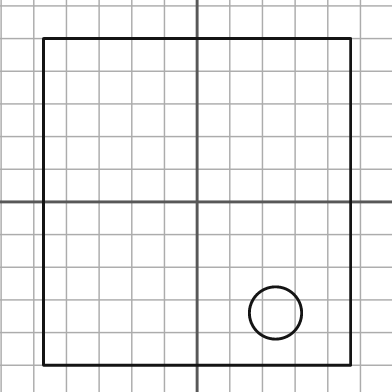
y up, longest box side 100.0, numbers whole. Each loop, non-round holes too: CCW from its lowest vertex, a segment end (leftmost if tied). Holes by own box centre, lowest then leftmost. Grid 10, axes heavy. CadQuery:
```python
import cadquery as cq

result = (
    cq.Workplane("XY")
    .moveTo(-47.0, -50.0)
    .lineTo(47.0, -50.0)
    .lineTo(47.0, 50.0)
    .lineTo(-47.0, 50.0)
    .close()
    .moveTo(24.0, -34.0)
    .circle(8.0)
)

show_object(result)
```